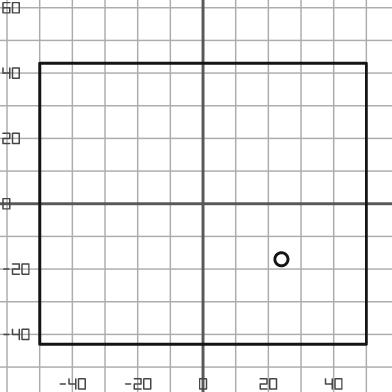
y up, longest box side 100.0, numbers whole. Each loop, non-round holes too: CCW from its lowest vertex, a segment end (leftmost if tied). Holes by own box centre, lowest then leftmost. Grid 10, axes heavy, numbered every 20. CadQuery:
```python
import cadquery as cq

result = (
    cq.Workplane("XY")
    .moveTo(-50.0, -43.0)
    .lineTo(50.0, -43.0)
    .lineTo(50.0, 43.0)
    .lineTo(-50.0, 43.0)
    .close()
    .moveTo(24.0, -17.0)
    .circle(2.0)
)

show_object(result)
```